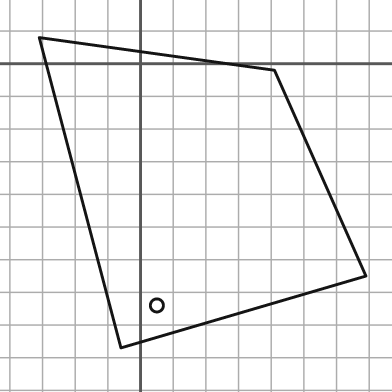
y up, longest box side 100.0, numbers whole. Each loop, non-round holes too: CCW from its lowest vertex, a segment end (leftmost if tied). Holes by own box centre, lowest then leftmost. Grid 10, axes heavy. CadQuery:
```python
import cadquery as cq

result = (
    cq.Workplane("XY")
    .moveTo(-6.0, -87.0)
    .lineTo(69.0, -65.0)
    .lineTo(41.0, -2.0)
    .lineTo(-31.0, 8.0)
    .close()
    .moveTo(5.0, -74.0)
    .circle(2.0)
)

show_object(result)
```